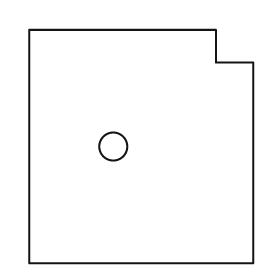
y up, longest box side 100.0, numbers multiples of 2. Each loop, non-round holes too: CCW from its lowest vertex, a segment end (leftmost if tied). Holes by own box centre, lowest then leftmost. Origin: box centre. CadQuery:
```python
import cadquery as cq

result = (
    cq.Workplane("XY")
    .moveTo(-48.0, -50.0)
    .lineTo(48.0, -50.0)
    .lineTo(48.0, 36.0)
    .lineTo(32.0, 36.0)
    .lineTo(32.0, 50.0)
    .lineTo(-48.0, 50.0)
    .close()
    .moveTo(-12.0, 0.0)
    .circle(6.0)
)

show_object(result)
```